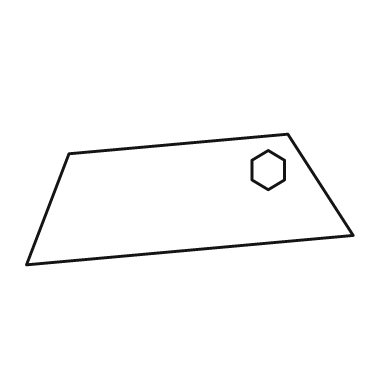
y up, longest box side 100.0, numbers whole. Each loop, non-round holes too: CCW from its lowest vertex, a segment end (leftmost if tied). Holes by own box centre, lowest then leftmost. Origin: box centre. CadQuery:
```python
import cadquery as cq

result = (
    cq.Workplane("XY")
    .moveTo(-50.0, -20.0)
    .lineTo(50.0, -11.0)
    .lineTo(30.0, 20.0)
    .lineTo(-37.0, 14.0)
    .close()
    .moveTo(24.0, 3.0)
    .lineTo(29.0, 6.0)
    .lineTo(29.0, 12.0)
    .lineTo(24.0, 15.0)
    .lineTo(19.0, 12.0)
    .lineTo(19.0, 6.0)
    .close()
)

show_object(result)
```